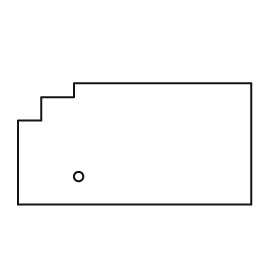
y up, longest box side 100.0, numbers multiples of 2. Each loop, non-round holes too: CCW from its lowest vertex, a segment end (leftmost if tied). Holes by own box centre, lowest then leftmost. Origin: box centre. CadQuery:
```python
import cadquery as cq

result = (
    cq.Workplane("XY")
    .moveTo(-50.0, -26.0)
    .lineTo(50.0, -26.0)
    .lineTo(50.0, 26.0)
    .lineTo(-26.0, 26.0)
    .lineTo(-26.0, 20.0)
    .lineTo(-40.0, 20.0)
    .lineTo(-40.0, 10.0)
    .lineTo(-50.0, 10.0)
    .close()
    .moveTo(-24.0, -14.0)
    .circle(2.0)
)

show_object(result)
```